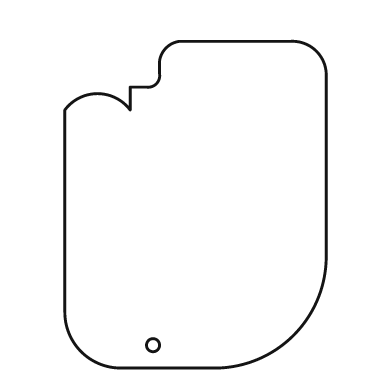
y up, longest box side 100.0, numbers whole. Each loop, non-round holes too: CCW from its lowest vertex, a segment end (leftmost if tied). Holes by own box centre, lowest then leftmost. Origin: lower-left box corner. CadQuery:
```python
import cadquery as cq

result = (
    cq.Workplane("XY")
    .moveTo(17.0, 0.0)
    .lineTo(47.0, 0.0)
    .threePointArc((70.0, 10.0), (80.0, 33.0))
    .lineTo(80.0, 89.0)
    .threePointArc((77.0, 97.0), (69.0, 100.0))
    .lineTo(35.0, 100.0)
    .threePointArc((31.0, 98.0), (29.0, 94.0))
    .lineTo(29.0, 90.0)
    .threePointArc((28.0, 87.0), (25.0, 86.0))
    .lineTo(20.0, 86.0)
    .lineTo(20.0, 79.0)
    .threePointArc((10.0, 84.0), (0.0, 79.0))
    .lineTo(0.0, 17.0)
    .threePointArc((5.0, 5.0), (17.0, 0.0))
    .close()
    .moveTo(27.0, 7.0)
    .circle(2.0)
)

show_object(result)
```